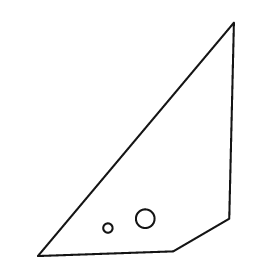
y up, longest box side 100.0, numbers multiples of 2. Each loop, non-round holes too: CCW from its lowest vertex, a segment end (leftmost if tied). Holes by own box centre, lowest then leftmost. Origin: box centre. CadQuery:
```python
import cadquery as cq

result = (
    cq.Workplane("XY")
    .moveTo(-42.0, -50.0)
    .lineTo(16.0, -48.0)
    .lineTo(40.0, -34.0)
    .lineTo(42.0, 50.0)
    .close()
    .moveTo(-12.0, -38.0)
    .circle(2.0)
    .moveTo(4.0, -34.0)
    .circle(4.0)
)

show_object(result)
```